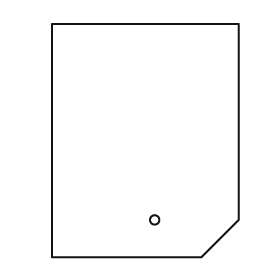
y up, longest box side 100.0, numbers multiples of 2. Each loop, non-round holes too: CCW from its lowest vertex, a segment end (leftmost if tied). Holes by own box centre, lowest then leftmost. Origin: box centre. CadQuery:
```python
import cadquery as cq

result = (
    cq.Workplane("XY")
    .moveTo(-40.0, -50.0)
    .lineTo(24.0, -50.0)
    .lineTo(40.0, -34.0)
    .lineTo(40.0, 50.0)
    .lineTo(-40.0, 50.0)
    .close()
    .moveTo(4.0, -34.0)
    .circle(2.0)
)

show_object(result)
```